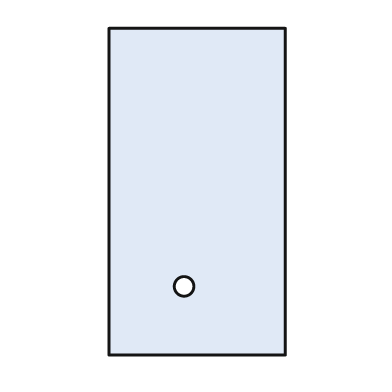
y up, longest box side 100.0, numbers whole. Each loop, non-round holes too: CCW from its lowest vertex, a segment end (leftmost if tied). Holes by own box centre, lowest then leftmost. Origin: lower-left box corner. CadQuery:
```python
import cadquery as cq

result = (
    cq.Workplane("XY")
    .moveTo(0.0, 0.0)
    .lineTo(54.0, 0.0)
    .lineTo(54.0, 100.0)
    .lineTo(0.0, 100.0)
    .close()
    .moveTo(23.0, 21.0)
    .circle(3.0)
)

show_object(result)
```